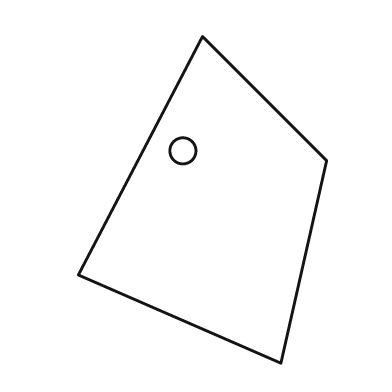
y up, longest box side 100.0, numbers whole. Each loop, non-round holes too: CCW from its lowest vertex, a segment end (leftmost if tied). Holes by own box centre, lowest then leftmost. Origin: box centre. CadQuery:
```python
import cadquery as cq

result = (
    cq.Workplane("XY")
    .moveTo(24.0, -50.0)
    .lineTo(38.0, 12.0)
    .lineTo(0.0, 50.0)
    .lineTo(-38.0, -23.0)
    .close()
    .moveTo(-6.0, 15.0)
    .circle(4.0)
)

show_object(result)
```